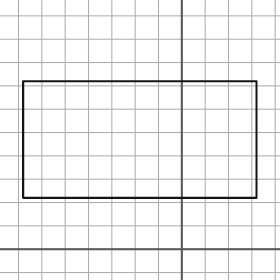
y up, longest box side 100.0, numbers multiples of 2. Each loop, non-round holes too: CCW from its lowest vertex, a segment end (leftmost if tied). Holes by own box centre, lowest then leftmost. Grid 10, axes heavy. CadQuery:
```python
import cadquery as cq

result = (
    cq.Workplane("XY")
    .moveTo(-68.0, 22.0)
    .lineTo(32.0, 22.0)
    .lineTo(32.0, 72.0)
    .lineTo(-68.0, 72.0)
    .close()
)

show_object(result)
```